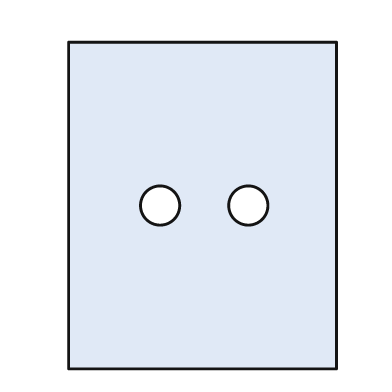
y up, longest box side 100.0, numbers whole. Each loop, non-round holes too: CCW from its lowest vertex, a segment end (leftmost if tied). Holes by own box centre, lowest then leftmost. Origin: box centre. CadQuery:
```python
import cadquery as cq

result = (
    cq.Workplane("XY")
    .moveTo(-41.0, -50.0)
    .lineTo(41.0, -50.0)
    .lineTo(41.0, 50.0)
    .lineTo(-41.0, 50.0)
    .close()
    .moveTo(-13.0, 0.0)
    .circle(6.0)
    .moveTo(14.0, 0.0)
    .circle(6.0)
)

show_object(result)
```